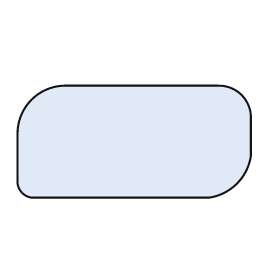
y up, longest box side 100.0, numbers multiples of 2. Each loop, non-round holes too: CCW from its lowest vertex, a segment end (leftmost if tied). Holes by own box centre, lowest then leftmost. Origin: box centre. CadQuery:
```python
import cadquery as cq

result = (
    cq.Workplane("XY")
    .moveTo(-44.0, -24.0)
    .lineTo(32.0, -24.0)
    .threePointArc((44.0, -18.0), (50.0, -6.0))
    .lineTo(50.0, 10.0)
    .threePointArc((46.0, 20.0), (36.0, 24.0))
    .lineTo(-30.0, 24.0)
    .threePointArc((-44.0, 18.0), (-50.0, 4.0))
    .lineTo(-50.0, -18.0)
    .threePointArc((-48.0, -22.0), (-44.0, -24.0))
    .close()
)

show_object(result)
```